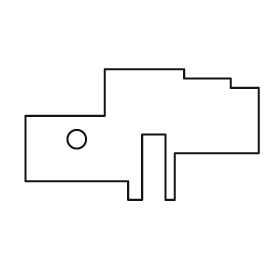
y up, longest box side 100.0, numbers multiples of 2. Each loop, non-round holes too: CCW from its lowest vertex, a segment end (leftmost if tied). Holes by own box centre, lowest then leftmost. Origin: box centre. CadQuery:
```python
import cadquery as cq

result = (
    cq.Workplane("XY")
    .moveTo(-6.0, -28.0)
    .lineTo(0.0, -28.0)
    .lineTo(0.0, 0.0)
    .lineTo(10.0, 0.0)
    .lineTo(10.0, -28.0)
    .lineTo(14.0, -28.0)
    .lineTo(14.0, -8.0)
    .lineTo(50.0, -8.0)
    .lineTo(50.0, 20.0)
    .lineTo(38.0, 20.0)
    .lineTo(38.0, 24.0)
    .lineTo(18.0, 24.0)
    .lineTo(18.0, 28.0)
    .lineTo(-16.0, 28.0)
    .lineTo(-16.0, 8.0)
    .lineTo(-50.0, 8.0)
    .lineTo(-50.0, -20.0)
    .lineTo(-6.0, -20.0)
    .close()
    .moveTo(-28.0, -2.0)
    .circle(4.0)
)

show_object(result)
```